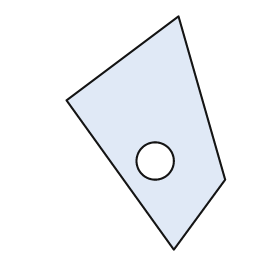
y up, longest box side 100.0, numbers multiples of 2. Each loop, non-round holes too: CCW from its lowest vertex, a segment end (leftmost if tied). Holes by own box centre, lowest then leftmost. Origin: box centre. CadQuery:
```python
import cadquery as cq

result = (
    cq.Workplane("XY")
    .moveTo(12.0, -50.0)
    .lineTo(34.0, -20.0)
    .lineTo(14.0, 50.0)
    .lineTo(-34.0, 14.0)
    .close()
    .moveTo(4.0, -12.0)
    .circle(8.0)
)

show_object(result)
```